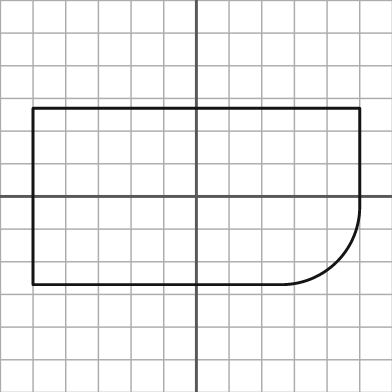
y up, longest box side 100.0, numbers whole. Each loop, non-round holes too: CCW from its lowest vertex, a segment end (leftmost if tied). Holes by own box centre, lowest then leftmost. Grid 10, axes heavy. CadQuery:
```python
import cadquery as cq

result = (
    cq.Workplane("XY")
    .moveTo(-50.0, -27.0)
    .lineTo(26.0, -27.0)
    .threePointArc((43.0, -20.0), (50.0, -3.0))
    .lineTo(50.0, 27.0)
    .lineTo(-50.0, 27.0)
    .close()
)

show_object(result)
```